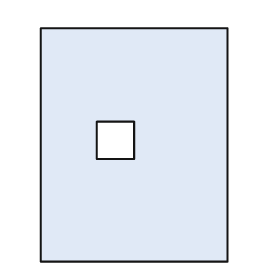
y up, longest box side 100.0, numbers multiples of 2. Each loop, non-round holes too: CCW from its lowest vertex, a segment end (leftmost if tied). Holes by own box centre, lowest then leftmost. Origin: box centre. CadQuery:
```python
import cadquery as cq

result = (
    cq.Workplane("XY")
    .moveTo(-40.0, -50.0)
    .lineTo(40.0, -50.0)
    .lineTo(40.0, 50.0)
    .lineTo(-40.0, 50.0)
    .close()
    .moveTo(-16.0, -6.0)
    .lineTo(0.0, -6.0)
    .lineTo(0.0, 10.0)
    .lineTo(-16.0, 10.0)
    .close()
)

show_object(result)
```